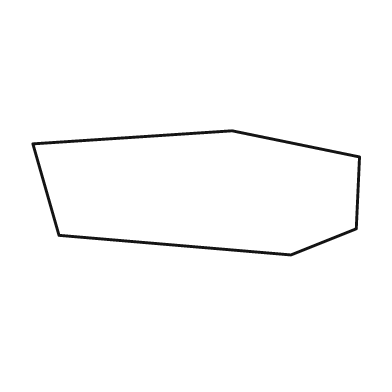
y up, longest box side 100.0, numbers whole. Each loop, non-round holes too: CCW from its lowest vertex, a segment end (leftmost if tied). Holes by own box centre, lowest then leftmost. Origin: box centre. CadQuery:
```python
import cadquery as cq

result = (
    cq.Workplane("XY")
    .moveTo(29.0, -19.0)
    .lineTo(49.0, -11.0)
    .lineTo(50.0, 11.0)
    .lineTo(11.0, 19.0)
    .lineTo(-50.0, 15.0)
    .lineTo(-42.0, -13.0)
    .close()
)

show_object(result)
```